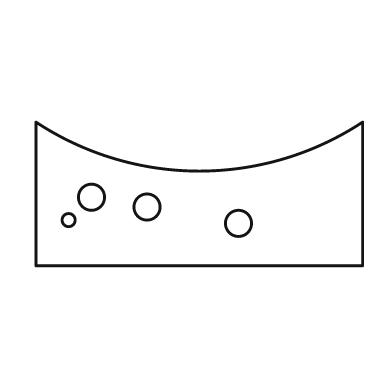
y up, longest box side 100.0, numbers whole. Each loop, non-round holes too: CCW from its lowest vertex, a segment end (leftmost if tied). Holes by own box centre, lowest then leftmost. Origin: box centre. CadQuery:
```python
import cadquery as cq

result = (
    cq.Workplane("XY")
    .moveTo(-50.0, -22.0)
    .lineTo(50.0, -22.0)
    .lineTo(50.0, 22.0)
    .threePointArc((0.0, 7.0), (-50.0, 22.0))
    .close()
    .moveTo(12.0, -9.0)
    .circle(4.0)
    .moveTo(-40.0, -8.0)
    .circle(2.0)
    .moveTo(-16.0, -4.0)
    .circle(4.0)
    .moveTo(-33.0, -1.0)
    .circle(4.0)
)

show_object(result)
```